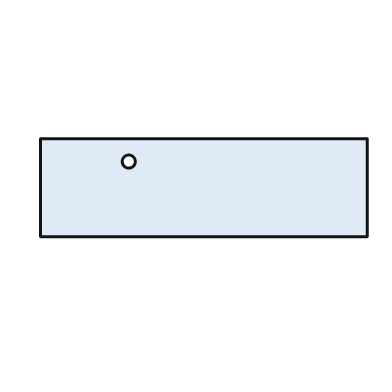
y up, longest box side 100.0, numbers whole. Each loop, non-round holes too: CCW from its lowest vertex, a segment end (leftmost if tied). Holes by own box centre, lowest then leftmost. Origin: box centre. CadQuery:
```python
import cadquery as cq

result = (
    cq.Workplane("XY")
    .moveTo(-50.0, -15.0)
    .lineTo(50.0, -15.0)
    .lineTo(50.0, 15.0)
    .lineTo(-50.0, 15.0)
    .close()
    .moveTo(-23.0, 8.0)
    .circle(2.0)
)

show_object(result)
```